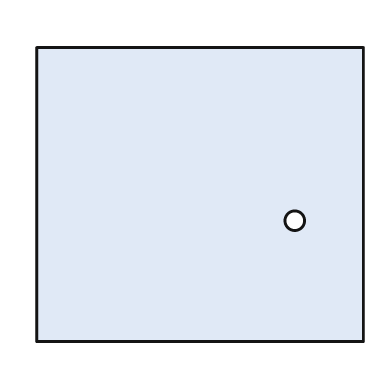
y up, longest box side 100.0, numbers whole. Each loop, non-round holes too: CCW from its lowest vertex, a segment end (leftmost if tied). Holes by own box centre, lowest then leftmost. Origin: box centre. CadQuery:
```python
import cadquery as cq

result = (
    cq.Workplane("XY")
    .moveTo(-50.0, -45.0)
    .lineTo(50.0, -45.0)
    .lineTo(50.0, 45.0)
    .lineTo(-50.0, 45.0)
    .close()
    .moveTo(29.0, -8.0)
    .circle(3.0)
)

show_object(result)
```